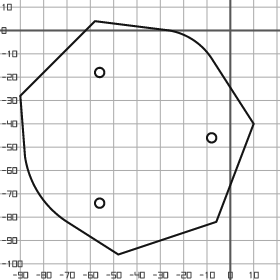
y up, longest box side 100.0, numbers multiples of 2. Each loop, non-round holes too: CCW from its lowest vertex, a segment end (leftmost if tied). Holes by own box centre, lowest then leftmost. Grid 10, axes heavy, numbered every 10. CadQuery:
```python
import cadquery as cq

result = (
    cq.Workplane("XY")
    .moveTo(-48.0, -96.0)
    .lineTo(-6.0, -82.0)
    .lineTo(10.0, -40.0)
    .lineTo(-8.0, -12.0)
    .threePointArc((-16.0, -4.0), (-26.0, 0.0))
    .lineTo(-58.0, 4.0)
    .lineTo(-90.0, -28.0)
    .lineTo(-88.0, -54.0)
    .threePointArc((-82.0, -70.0), (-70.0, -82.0))
    .close()
    .moveTo(-56.0, -74.0)
    .circle(2.0)
    .moveTo(-8.0, -46.0)
    .circle(2.0)
    .moveTo(-56.0, -18.0)
    .circle(2.0)
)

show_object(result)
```